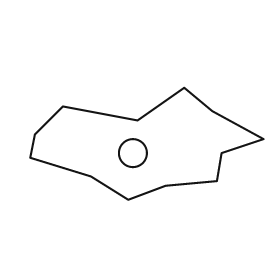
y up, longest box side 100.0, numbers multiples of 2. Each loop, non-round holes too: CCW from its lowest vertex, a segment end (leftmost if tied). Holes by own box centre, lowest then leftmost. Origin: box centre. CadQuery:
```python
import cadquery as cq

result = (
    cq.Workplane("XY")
    .moveTo(-8.0, -24.0)
    .lineTo(8.0, -18.0)
    .lineTo(30.0, -16.0)
    .lineTo(32.0, -4.0)
    .lineTo(50.0, 2.0)
    .lineTo(28.0, 14.0)
    .lineTo(16.0, 24.0)
    .lineTo(-4.0, 10.0)
    .lineTo(-36.0, 16.0)
    .lineTo(-48.0, 4.0)
    .lineTo(-50.0, -6.0)
    .lineTo(-24.0, -14.0)
    .close()
    .moveTo(-6.0, -4.0)
    .circle(6.0)
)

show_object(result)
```